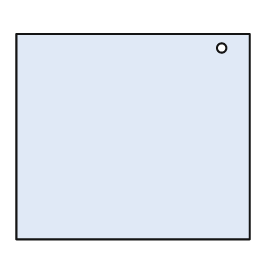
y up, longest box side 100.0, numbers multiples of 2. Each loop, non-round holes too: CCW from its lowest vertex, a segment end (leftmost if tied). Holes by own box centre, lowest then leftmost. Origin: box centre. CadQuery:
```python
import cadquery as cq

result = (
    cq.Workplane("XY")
    .moveTo(-50.0, -44.0)
    .lineTo(50.0, -44.0)
    .lineTo(50.0, 44.0)
    .lineTo(-50.0, 44.0)
    .close()
    .moveTo(38.0, 38.0)
    .circle(2.0)
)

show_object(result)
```